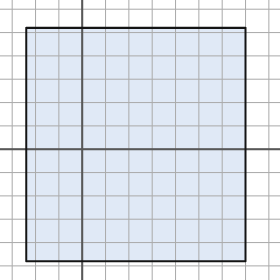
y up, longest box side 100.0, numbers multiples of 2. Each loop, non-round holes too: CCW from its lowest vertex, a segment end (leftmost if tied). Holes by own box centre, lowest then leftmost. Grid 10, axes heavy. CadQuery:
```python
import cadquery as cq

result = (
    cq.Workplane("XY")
    .moveTo(-24.0, -48.0)
    .lineTo(70.0, -48.0)
    .lineTo(70.0, 52.0)
    .lineTo(-24.0, 52.0)
    .close()
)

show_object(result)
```